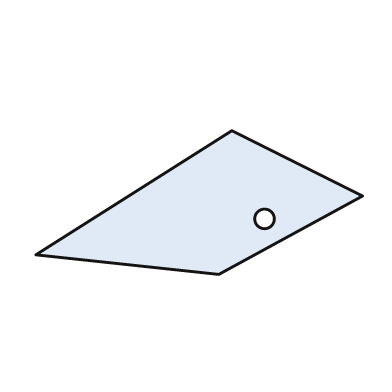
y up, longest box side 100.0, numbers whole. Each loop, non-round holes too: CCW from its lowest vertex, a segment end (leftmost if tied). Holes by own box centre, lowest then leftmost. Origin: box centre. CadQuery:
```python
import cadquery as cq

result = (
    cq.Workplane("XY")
    .moveTo(6.0, -22.0)
    .lineTo(50.0, 2.0)
    .lineTo(10.0, 22.0)
    .lineTo(-50.0, -16.0)
    .close()
    .moveTo(20.0, -5.0)
    .circle(3.0)
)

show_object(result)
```